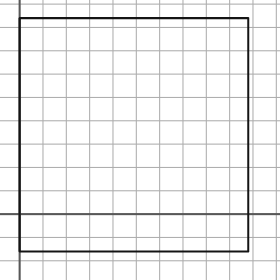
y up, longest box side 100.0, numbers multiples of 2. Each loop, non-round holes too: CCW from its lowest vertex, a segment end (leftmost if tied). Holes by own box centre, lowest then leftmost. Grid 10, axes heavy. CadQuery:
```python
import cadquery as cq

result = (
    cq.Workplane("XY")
    .moveTo(0.0, -16.0)
    .lineTo(98.0, -16.0)
    .lineTo(98.0, 84.0)
    .lineTo(0.0, 84.0)
    .close()
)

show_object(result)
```